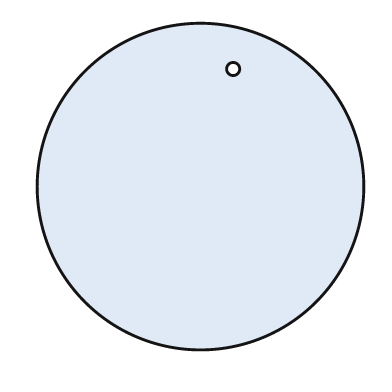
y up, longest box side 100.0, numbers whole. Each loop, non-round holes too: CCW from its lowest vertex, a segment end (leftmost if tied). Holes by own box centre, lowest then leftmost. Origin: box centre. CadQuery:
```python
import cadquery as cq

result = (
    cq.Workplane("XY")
    .moveTo(0.0, 0.0)
    .circle(50.0)
    .moveTo(10.0, 36.0)
    .circle(2.0)
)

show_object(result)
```